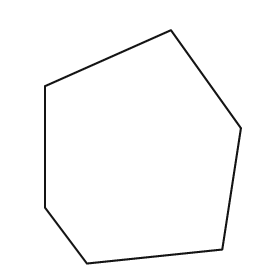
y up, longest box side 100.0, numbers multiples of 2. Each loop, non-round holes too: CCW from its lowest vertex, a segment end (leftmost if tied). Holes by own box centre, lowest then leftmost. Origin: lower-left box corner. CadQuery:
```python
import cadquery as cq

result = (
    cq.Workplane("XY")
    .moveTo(18.0, 0.0)
    .lineTo(76.0, 6.0)
    .lineTo(84.0, 58.0)
    .lineTo(54.0, 100.0)
    .lineTo(0.0, 76.0)
    .lineTo(0.0, 24.0)
    .close()
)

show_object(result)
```